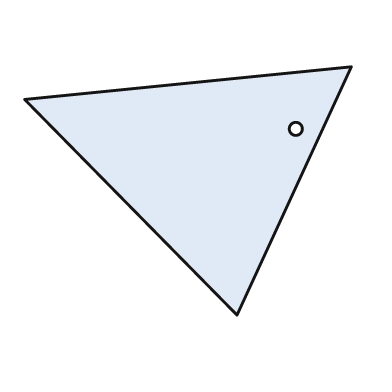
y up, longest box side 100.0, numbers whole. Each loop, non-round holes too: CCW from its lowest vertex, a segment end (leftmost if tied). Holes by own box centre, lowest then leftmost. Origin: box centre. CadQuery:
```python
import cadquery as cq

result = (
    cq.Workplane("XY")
    .moveTo(15.0, -38.0)
    .lineTo(50.0, 38.0)
    .lineTo(-50.0, 28.0)
    .close()
    .moveTo(33.0, 19.0)
    .circle(2.0)
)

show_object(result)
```